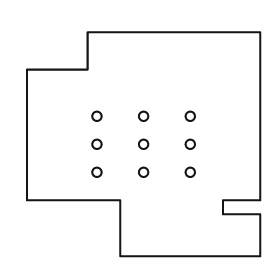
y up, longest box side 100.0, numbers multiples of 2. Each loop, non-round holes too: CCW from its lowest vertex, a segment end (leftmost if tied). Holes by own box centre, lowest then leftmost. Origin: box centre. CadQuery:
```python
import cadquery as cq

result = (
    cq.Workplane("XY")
    .moveTo(-10.0, -48.0)
    .lineTo(50.0, -48.0)
    .lineTo(50.0, -30.0)
    .lineTo(34.0, -30.0)
    .lineTo(34.0, -24.0)
    .lineTo(50.0, -24.0)
    .lineTo(50.0, 48.0)
    .lineTo(-24.0, 48.0)
    .lineTo(-24.0, 32.0)
    .lineTo(-50.0, 32.0)
    .lineTo(-50.0, -24.0)
    .lineTo(-10.0, -24.0)
    .close()
    .moveTo(-20.0, -12.0)
    .circle(2.0)
    .moveTo(0.0, -12.0)
    .circle(2.0)
    .moveTo(20.0, -12.0)
    .circle(2.0)
    .moveTo(-20.0, 0.0)
    .circle(2.0)
    .moveTo(0.0, 0.0)
    .circle(2.0)
    .moveTo(20.0, 0.0)
    .circle(2.0)
    .moveTo(-20.0, 12.0)
    .circle(2.0)
    .moveTo(0.0, 12.0)
    .circle(2.0)
    .moveTo(20.0, 12.0)
    .circle(2.0)
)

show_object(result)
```